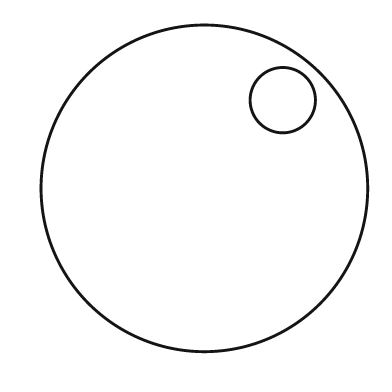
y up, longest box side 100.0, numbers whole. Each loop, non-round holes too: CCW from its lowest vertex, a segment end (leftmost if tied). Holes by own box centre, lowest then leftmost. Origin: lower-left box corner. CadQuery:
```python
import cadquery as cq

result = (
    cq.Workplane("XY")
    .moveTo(50.0, 50.0)
    .circle(50.0)
    .moveTo(74.0, 77.0)
    .circle(10.0)
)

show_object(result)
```